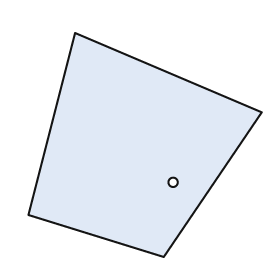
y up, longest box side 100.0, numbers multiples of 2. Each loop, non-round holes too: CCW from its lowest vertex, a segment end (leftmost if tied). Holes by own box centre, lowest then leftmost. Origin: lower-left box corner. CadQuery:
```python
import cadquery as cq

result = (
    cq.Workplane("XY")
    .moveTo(58.0, 0.0)
    .lineTo(100.0, 62.0)
    .lineTo(20.0, 96.0)
    .lineTo(0.0, 18.0)
    .close()
    .moveTo(62.0, 32.0)
    .circle(2.0)
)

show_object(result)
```